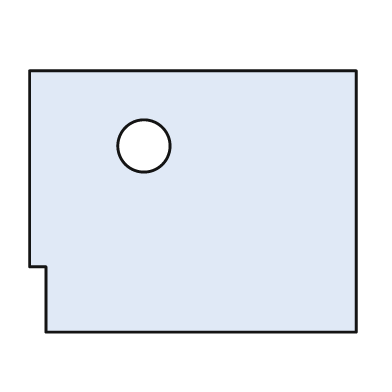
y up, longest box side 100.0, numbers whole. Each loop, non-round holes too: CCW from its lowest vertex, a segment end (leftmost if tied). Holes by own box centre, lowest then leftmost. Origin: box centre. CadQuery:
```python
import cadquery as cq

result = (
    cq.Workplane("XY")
    .moveTo(-45.0, -40.0)
    .lineTo(50.0, -40.0)
    .lineTo(50.0, 40.0)
    .lineTo(-50.0, 40.0)
    .lineTo(-50.0, -20.0)
    .lineTo(-45.0, -20.0)
    .close()
    .moveTo(-15.0, 17.0)
    .circle(8.0)
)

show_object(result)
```